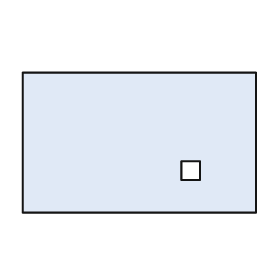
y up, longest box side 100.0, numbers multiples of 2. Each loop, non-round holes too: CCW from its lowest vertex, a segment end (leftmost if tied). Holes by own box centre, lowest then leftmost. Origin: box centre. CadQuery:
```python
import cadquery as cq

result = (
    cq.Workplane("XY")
    .moveTo(-50.0, -30.0)
    .lineTo(50.0, -30.0)
    .lineTo(50.0, 30.0)
    .lineTo(-50.0, 30.0)
    .close()
    .moveTo(18.0, -16.0)
    .lineTo(26.0, -16.0)
    .lineTo(26.0, -8.0)
    .lineTo(18.0, -8.0)
    .close()
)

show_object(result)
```